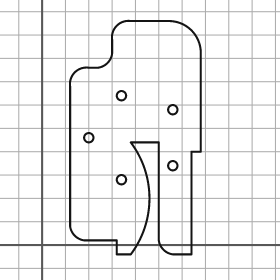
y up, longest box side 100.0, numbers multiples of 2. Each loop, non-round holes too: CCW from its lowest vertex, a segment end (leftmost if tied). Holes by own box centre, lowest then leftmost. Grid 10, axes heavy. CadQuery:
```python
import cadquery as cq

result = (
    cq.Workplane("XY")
    .moveTo(32.0, -4.0)
    .lineTo(38.0, -4.0)
    .threePointArc((46.0, 20.0), (38.0, 44.0))
    .lineTo(50.0, 44.0)
    .lineTo(50.0, 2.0)
    .threePointArc((52.0, -2.0), (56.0, -4.0))
    .lineTo(64.0, -4.0)
    .lineTo(64.0, 40.0)
    .lineTo(68.0, 40.0)
    .lineTo(68.0, 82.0)
    .threePointArc((64.0, 92.0), (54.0, 96.0))
    .lineTo(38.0, 96.0)
    .threePointArc((32.0, 94.0), (30.0, 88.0))
    .lineTo(30.0, 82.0)
    .threePointArc((28.0, 78.0), (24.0, 76.0))
    .lineTo(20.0, 76.0)
    .threePointArc((14.0, 74.0), (12.0, 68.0))
    .lineTo(12.0, 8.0)
    .threePointArc((14.0, 4.0), (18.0, 2.0))
    .lineTo(32.0, 2.0)
    .close()
    .moveTo(34.0, 28.0)
    .circle(2.0)
    .moveTo(56.0, 34.0)
    .circle(2.0)
    .moveTo(20.0, 46.0)
    .circle(2.0)
    .moveTo(56.0, 58.0)
    .circle(2.0)
    .moveTo(34.0, 64.0)
    .circle(2.0)
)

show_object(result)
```